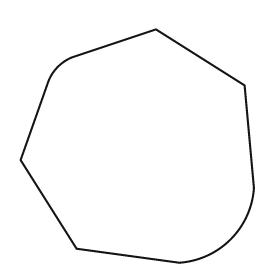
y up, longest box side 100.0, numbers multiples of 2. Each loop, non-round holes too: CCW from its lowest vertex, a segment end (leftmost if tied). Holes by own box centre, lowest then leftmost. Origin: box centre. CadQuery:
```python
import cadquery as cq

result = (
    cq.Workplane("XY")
    .moveTo(18.0, -50.0)
    .threePointArc((40.0, -40.0), (50.0, -18.0))
    .lineTo(46.0, 26.0)
    .lineTo(8.0, 50.0)
    .lineTo(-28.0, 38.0)
    .threePointArc((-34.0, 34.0), (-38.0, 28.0))
    .lineTo(-50.0, -6.0)
    .lineTo(-26.0, -44.0)
    .close()
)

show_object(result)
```